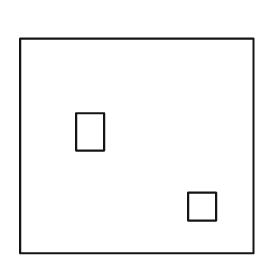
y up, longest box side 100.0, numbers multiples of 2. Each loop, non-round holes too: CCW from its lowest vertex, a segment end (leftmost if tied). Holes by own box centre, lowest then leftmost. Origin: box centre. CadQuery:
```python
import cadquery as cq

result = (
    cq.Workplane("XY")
    .moveTo(-50.0, -46.0)
    .lineTo(50.0, -46.0)
    .lineTo(50.0, 46.0)
    .lineTo(-50.0, 46.0)
    .close()
    .moveTo(22.0, -32.0)
    .lineTo(34.0, -32.0)
    .lineTo(34.0, -20.0)
    .lineTo(22.0, -20.0)
    .close()
    .moveTo(-26.0, -2.0)
    .lineTo(-14.0, -2.0)
    .lineTo(-14.0, 14.0)
    .lineTo(-26.0, 14.0)
    .close()
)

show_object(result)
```